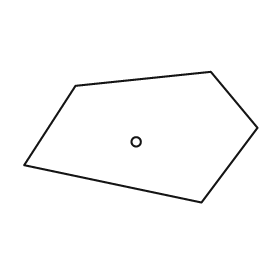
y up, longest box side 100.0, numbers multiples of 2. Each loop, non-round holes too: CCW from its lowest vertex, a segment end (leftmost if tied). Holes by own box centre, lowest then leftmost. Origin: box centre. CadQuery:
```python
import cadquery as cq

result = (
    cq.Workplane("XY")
    .moveTo(26.0, -28.0)
    .lineTo(50.0, 4.0)
    .lineTo(30.0, 28.0)
    .lineTo(-28.0, 22.0)
    .lineTo(-50.0, -12.0)
    .close()
    .moveTo(-2.0, -2.0)
    .circle(2.0)
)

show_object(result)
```